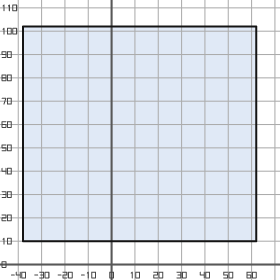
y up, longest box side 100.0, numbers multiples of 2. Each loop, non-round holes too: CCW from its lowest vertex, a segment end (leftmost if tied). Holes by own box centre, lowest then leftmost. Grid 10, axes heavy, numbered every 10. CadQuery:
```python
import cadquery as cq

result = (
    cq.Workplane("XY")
    .moveTo(-38.0, 10.0)
    .lineTo(62.0, 10.0)
    .lineTo(62.0, 102.0)
    .lineTo(-38.0, 102.0)
    .close()
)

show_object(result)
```